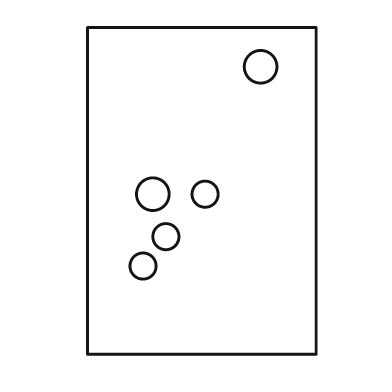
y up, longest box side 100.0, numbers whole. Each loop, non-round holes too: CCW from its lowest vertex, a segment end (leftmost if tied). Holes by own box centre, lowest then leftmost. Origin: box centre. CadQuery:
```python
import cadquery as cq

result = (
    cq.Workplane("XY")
    .moveTo(-35.0, -50.0)
    .lineTo(35.0, -50.0)
    .lineTo(35.0, 50.0)
    .lineTo(-35.0, 50.0)
    .close()
    .moveTo(-18.0, -23.0)
    .circle(4.0)
    .moveTo(-11.0, -14.0)
    .circle(4.0)
    .moveTo(-15.0, -1.0)
    .circle(5.0)
    .moveTo(1.0, -1.0)
    .circle(4.0)
    .moveTo(18.0, 38.0)
    .circle(5.0)
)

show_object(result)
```